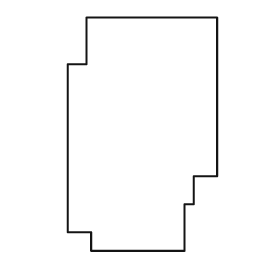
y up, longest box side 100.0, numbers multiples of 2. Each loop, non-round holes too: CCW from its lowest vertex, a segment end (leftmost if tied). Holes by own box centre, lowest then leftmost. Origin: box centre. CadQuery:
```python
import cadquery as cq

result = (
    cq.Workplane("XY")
    .moveTo(-22.0, -50.0)
    .lineTo(18.0, -50.0)
    .lineTo(18.0, -30.0)
    .lineTo(22.0, -30.0)
    .lineTo(22.0, -18.0)
    .lineTo(32.0, -18.0)
    .lineTo(32.0, 50.0)
    .lineTo(-24.0, 50.0)
    .lineTo(-24.0, 30.0)
    .lineTo(-32.0, 30.0)
    .lineTo(-32.0, -42.0)
    .lineTo(-22.0, -42.0)
    .close()
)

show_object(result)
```